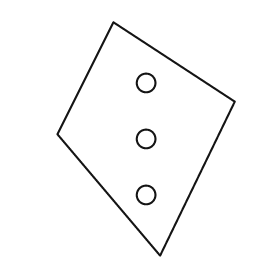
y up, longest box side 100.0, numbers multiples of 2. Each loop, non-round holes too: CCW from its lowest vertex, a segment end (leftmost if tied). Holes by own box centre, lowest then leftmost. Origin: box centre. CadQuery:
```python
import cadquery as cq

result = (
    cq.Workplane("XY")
    .moveTo(6.0, -50.0)
    .lineTo(38.0, 16.0)
    .lineTo(-14.0, 50.0)
    .lineTo(-38.0, 2.0)
    .close()
    .moveTo(0.0, -24.0)
    .circle(4.0)
    .moveTo(0.0, 0.0)
    .circle(4.0)
    .moveTo(0.0, 24.0)
    .circle(4.0)
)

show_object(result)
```